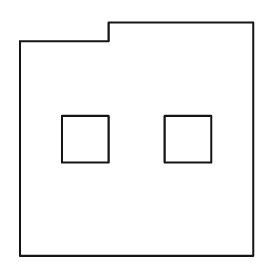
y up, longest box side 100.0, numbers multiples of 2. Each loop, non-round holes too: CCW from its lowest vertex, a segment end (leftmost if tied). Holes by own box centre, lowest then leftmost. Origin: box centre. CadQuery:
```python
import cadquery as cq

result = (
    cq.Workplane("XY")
    .moveTo(-50.0, -50.0)
    .lineTo(50.0, -50.0)
    .lineTo(50.0, 50.0)
    .lineTo(-12.0, 50.0)
    .lineTo(-12.0, 42.0)
    .lineTo(-50.0, 42.0)
    .close()
    .moveTo(-32.0, -10.0)
    .lineTo(-12.0, -10.0)
    .lineTo(-12.0, 10.0)
    .lineTo(-32.0, 10.0)
    .close()
    .moveTo(12.0, -10.0)
    .lineTo(32.0, -10.0)
    .lineTo(32.0, 10.0)
    .lineTo(12.0, 10.0)
    .close()
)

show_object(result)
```